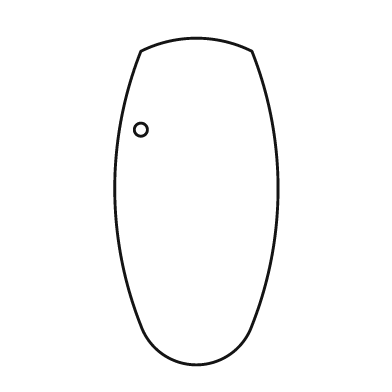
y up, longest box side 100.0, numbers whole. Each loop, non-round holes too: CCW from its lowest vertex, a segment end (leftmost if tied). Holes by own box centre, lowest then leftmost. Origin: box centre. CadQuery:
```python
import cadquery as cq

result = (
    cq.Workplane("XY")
    .moveTo(-17.0, -38.0)
    .threePointArc((0.0, -50.0), (17.0, -38.0))
    .threePointArc((25.0, 4.0), (17.0, 46.0))
    .threePointArc((0.0, 50.0), (-17.0, 46.0))
    .threePointArc((-25.0, 4.0), (-17.0, -38.0))
    .close()
    .moveTo(-17.0, 22.0)
    .circle(2.0)
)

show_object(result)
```